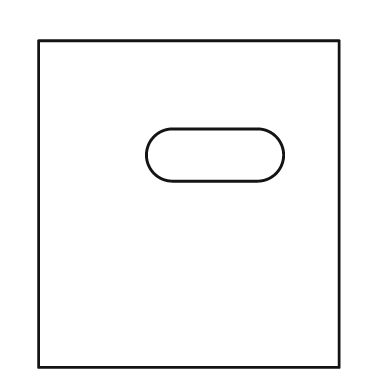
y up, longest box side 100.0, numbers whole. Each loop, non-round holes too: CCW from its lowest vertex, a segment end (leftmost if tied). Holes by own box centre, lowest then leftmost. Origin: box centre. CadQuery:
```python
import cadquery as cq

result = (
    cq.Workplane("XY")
    .moveTo(-46.0, -50.0)
    .lineTo(46.0, -50.0)
    .lineTo(46.0, 50.0)
    .lineTo(-46.0, 50.0)
    .close()
    .moveTo(-5.0, 7.0)
    .lineTo(21.0, 7.0)
    .threePointArc((29.0, 15.0), (21.0, 23.0))
    .lineTo(-5.0, 23.0)
    .threePointArc((-13.0, 15.0), (-5.0, 7.0))
    .close()
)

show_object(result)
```